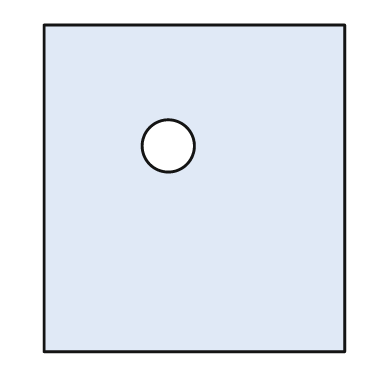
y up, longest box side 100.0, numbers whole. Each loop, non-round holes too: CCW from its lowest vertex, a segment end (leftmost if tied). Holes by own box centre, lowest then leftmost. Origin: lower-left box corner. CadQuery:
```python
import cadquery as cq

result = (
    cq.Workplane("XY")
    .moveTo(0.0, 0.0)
    .lineTo(92.0, 0.0)
    .lineTo(92.0, 100.0)
    .lineTo(0.0, 100.0)
    .close()
    .moveTo(38.0, 63.0)
    .circle(8.0)
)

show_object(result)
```